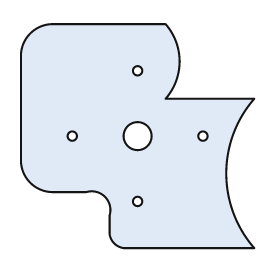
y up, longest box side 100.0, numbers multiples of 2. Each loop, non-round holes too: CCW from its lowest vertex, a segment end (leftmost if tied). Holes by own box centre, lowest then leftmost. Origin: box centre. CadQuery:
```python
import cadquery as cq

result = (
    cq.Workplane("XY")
    .moveTo(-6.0, -48.0)
    .lineTo(50.0, -48.0)
    .threePointArc((38.0, -16.0), (50.0, 16.0))
    .lineTo(12.0, 16.0)
    .threePointArc((18.0, 32.0), (12.0, 48.0))
    .lineTo(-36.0, 48.0)
    .threePointArc((-46.0, 44.0), (-50.0, 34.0))
    .lineTo(-50.0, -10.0)
    .threePointArc((-46.0, -20.0), (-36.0, -24.0))
    .lineTo(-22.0, -24.0)
    .threePointArc((-14.0, -26.0), (-12.0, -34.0))
    .lineTo(-12.0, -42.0)
    .threePointArc((-10.0, -46.0), (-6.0, -48.0))
    .close()
    .moveTo(0.0, -28.0)
    .circle(2.0)
    .moveTo(-28.0, 0.0)
    .circle(2.0)
    .moveTo(0.0, 0.0)
    .circle(6.0)
    .moveTo(28.0, 0.0)
    .circle(2.0)
    .moveTo(0.0, 28.0)
    .circle(2.0)
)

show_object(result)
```